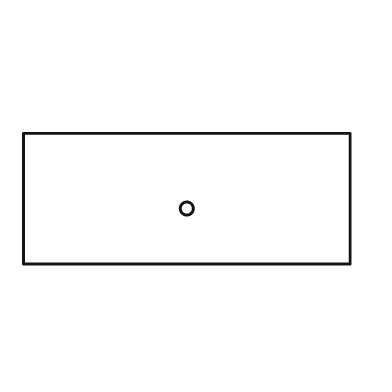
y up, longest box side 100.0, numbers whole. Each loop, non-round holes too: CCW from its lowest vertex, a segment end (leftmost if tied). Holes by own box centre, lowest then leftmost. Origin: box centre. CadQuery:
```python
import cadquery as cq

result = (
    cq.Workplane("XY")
    .moveTo(-50.0, -20.0)
    .lineTo(50.0, -20.0)
    .lineTo(50.0, 20.0)
    .lineTo(-50.0, 20.0)
    .close()
    .moveTo(0.0, -3.0)
    .circle(2.0)
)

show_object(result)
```